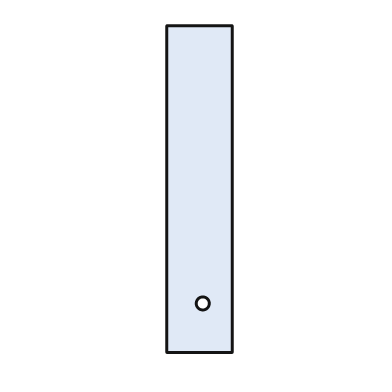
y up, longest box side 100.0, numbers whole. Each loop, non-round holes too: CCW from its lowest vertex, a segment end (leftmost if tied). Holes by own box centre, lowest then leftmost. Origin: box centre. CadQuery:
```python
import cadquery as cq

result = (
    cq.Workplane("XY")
    .moveTo(-10.0, -50.0)
    .lineTo(10.0, -50.0)
    .lineTo(10.0, 50.0)
    .lineTo(-10.0, 50.0)
    .close()
    .moveTo(1.0, -35.0)
    .circle(2.0)
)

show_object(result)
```